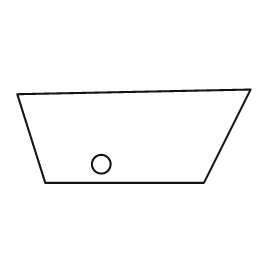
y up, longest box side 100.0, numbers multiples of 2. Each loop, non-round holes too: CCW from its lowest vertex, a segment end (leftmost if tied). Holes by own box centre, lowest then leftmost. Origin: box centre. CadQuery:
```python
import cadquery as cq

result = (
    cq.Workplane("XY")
    .moveTo(-38.0, -20.0)
    .lineTo(30.0, -20.0)
    .lineTo(50.0, 20.0)
    .lineTo(-50.0, 18.0)
    .close()
    .moveTo(-14.0, -12.0)
    .circle(4.0)
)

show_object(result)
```